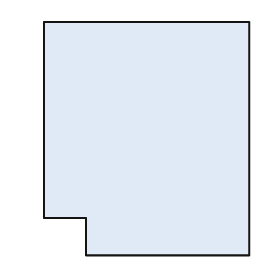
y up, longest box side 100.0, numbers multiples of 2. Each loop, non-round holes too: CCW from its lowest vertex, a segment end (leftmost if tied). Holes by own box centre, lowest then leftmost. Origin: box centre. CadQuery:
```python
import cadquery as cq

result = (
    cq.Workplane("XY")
    .moveTo(-26.0, -50.0)
    .lineTo(44.0, -50.0)
    .lineTo(44.0, 50.0)
    .lineTo(-44.0, 50.0)
    .lineTo(-44.0, -34.0)
    .lineTo(-26.0, -34.0)
    .close()
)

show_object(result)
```